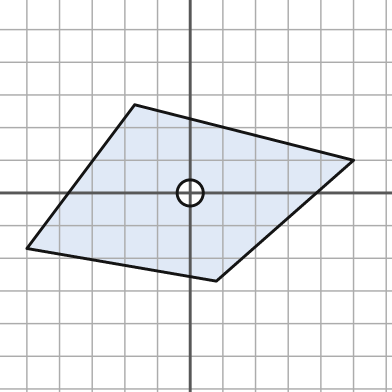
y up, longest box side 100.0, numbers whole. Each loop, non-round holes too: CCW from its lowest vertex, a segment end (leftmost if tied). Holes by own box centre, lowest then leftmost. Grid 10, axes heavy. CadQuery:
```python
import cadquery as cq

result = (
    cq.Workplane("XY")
    .moveTo(8.0, -27.0)
    .lineTo(50.0, 10.0)
    .lineTo(-17.0, 27.0)
    .lineTo(-50.0, -17.0)
    .close()
    .moveTo(0.0, 0.0)
    .circle(4.0)
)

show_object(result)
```